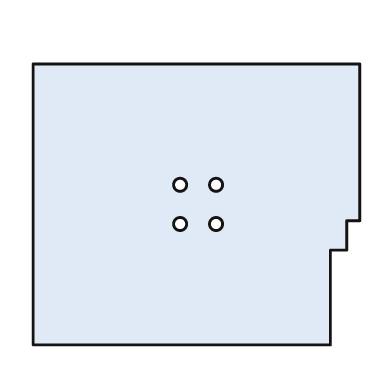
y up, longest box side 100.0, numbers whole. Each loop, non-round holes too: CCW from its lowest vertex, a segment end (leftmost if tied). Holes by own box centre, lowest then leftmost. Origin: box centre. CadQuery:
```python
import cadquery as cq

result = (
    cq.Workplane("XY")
    .moveTo(-50.0, -43.0)
    .lineTo(41.0, -43.0)
    .lineTo(41.0, -14.0)
    .lineTo(46.0, -14.0)
    .lineTo(46.0, -5.0)
    .lineTo(50.0, -5.0)
    .lineTo(50.0, 43.0)
    .lineTo(-50.0, 43.0)
    .close()
    .moveTo(-5.0, -6.0)
    .circle(2.0)
    .moveTo(6.0, -6.0)
    .circle(2.0)
    .moveTo(-5.0, 6.0)
    .circle(2.0)
    .moveTo(6.0, 6.0)
    .circle(2.0)
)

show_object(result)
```